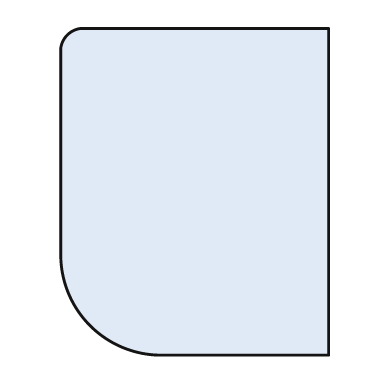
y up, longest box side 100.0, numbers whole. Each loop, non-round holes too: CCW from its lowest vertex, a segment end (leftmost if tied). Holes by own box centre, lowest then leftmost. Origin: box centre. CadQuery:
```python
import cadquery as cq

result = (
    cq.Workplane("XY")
    .moveTo(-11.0, -50.0)
    .lineTo(41.0, -50.0)
    .lineTo(41.0, 50.0)
    .lineTo(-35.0, 50.0)
    .threePointArc((-39.0, 48.0), (-41.0, 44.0))
    .lineTo(-41.0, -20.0)
    .threePointArc((-32.0, -41.0), (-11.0, -50.0))
    .close()
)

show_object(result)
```